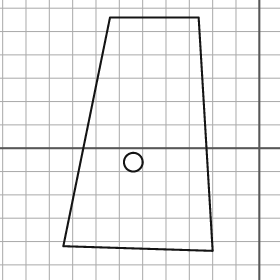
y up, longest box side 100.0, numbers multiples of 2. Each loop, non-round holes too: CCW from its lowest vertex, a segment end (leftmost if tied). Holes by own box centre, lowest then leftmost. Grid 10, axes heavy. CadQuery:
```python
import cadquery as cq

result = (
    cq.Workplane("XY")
    .moveTo(-20.0, -44.0)
    .lineTo(-26.0, 56.0)
    .lineTo(-64.0, 56.0)
    .lineTo(-84.0, -42.0)
    .close()
    .moveTo(-54.0, -6.0)
    .circle(4.0)
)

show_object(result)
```